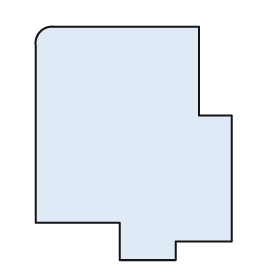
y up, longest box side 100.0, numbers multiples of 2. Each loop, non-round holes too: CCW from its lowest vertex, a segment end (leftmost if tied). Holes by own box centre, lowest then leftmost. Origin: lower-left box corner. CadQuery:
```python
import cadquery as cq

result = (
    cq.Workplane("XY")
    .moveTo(36.0, 0.0)
    .lineTo(60.0, 0.0)
    .lineTo(60.0, 8.0)
    .lineTo(84.0, 8.0)
    .lineTo(84.0, 62.0)
    .lineTo(70.0, 62.0)
    .lineTo(70.0, 100.0)
    .lineTo(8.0, 100.0)
    .threePointArc((2.0, 98.0), (0.0, 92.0))
    .lineTo(0.0, 16.0)
    .lineTo(36.0, 16.0)
    .close()
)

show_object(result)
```